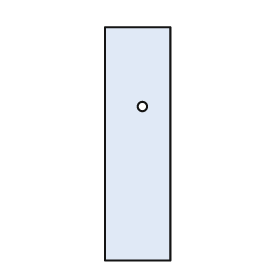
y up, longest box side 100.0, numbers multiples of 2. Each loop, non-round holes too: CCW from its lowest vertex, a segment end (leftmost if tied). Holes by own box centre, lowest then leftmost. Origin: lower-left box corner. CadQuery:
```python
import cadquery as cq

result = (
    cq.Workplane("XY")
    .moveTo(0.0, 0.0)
    .lineTo(28.0, 0.0)
    .lineTo(28.0, 100.0)
    .lineTo(0.0, 100.0)
    .close()
    .moveTo(16.0, 66.0)
    .circle(2.0)
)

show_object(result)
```